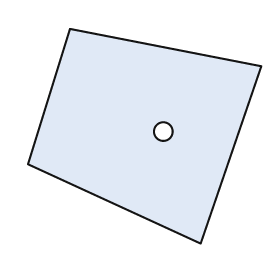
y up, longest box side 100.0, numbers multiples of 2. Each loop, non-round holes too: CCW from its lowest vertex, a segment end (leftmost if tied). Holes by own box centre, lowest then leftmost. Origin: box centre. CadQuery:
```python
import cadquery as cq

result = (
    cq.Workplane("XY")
    .moveTo(24.0, -46.0)
    .lineTo(50.0, 30.0)
    .lineTo(-32.0, 46.0)
    .lineTo(-50.0, -12.0)
    .close()
    .moveTo(8.0, 2.0)
    .circle(4.0)
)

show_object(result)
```